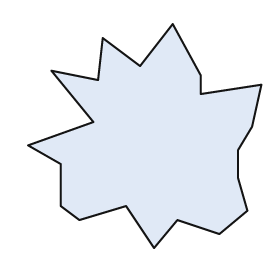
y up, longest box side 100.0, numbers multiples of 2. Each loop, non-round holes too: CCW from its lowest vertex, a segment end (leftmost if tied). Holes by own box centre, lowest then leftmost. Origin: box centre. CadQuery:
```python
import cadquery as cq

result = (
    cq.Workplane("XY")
    .moveTo(4.0, -48.0)
    .lineTo(14.0, -36.0)
    .lineTo(32.0, -42.0)
    .lineTo(44.0, -32.0)
    .lineTo(40.0, -18.0)
    .lineTo(40.0, -6.0)
    .lineTo(46.0, 4.0)
    .lineTo(50.0, 22.0)
    .lineTo(24.0, 18.0)
    .lineTo(24.0, 26.0)
    .lineTo(12.0, 48.0)
    .lineTo(-2.0, 30.0)
    .lineTo(-18.0, 42.0)
    .lineTo(-20.0, 24.0)
    .lineTo(-40.0, 28.0)
    .lineTo(-22.0, 6.0)
    .lineTo(-50.0, -4.0)
    .lineTo(-36.0, -12.0)
    .lineTo(-36.0, -30.0)
    .lineTo(-28.0, -36.0)
    .lineTo(-8.0, -30.0)
    .close()
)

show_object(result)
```